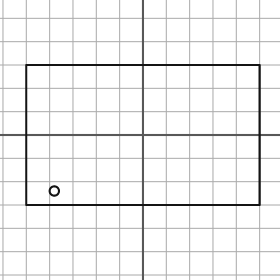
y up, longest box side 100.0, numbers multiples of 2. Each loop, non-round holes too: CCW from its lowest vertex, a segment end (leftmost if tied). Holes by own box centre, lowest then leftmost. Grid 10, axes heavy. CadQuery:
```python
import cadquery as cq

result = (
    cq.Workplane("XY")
    .moveTo(-50.0, -30.0)
    .lineTo(50.0, -30.0)
    .lineTo(50.0, 30.0)
    .lineTo(-50.0, 30.0)
    .close()
    .moveTo(-38.0, -24.0)
    .circle(2.0)
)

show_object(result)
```